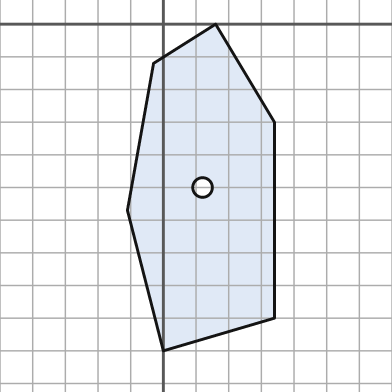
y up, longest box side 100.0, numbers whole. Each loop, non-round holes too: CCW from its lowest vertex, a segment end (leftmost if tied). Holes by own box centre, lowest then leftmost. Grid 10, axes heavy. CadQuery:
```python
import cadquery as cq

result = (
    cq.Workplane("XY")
    .moveTo(0.0, -100.0)
    .lineTo(34.0, -90.0)
    .lineTo(34.0, -30.0)
    .lineTo(16.0, 0.0)
    .lineTo(-3.0, -12.0)
    .lineTo(-11.0, -57.0)
    .close()
    .moveTo(12.0, -50.0)
    .circle(3.0)
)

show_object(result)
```